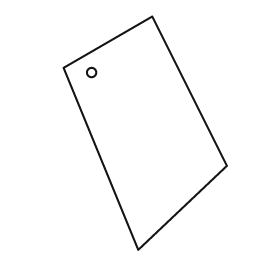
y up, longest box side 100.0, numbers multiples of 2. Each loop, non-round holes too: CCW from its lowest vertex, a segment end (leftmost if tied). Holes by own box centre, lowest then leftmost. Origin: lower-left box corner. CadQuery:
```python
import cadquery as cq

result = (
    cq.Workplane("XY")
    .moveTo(32.0, 0.0)
    .lineTo(70.0, 36.0)
    .lineTo(38.0, 100.0)
    .lineTo(0.0, 78.0)
    .close()
    .moveTo(12.0, 76.0)
    .circle(2.0)
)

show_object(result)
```